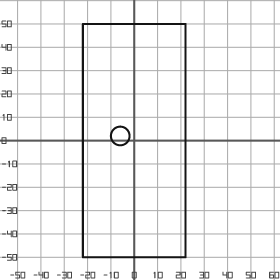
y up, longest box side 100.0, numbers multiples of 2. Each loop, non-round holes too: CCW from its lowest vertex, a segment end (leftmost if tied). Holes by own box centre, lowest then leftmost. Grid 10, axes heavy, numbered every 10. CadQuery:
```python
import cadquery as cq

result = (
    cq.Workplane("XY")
    .moveTo(-22.0, -50.0)
    .lineTo(22.0, -50.0)
    .lineTo(22.0, 50.0)
    .lineTo(-22.0, 50.0)
    .close()
    .moveTo(-6.0, 2.0)
    .circle(4.0)
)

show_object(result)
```